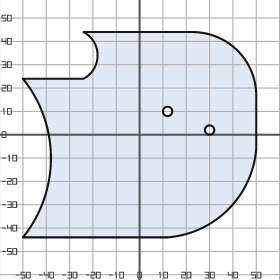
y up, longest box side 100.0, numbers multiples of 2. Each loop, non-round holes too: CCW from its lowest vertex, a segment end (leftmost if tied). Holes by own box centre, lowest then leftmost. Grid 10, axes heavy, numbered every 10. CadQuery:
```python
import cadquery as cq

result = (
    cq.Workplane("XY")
    .moveTo(-50.0, -44.0)
    .lineTo(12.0, -44.0)
    .threePointArc((38.0, -32.0), (50.0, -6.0))
    .lineTo(50.0, 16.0)
    .threePointArc((42.0, 36.0), (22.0, 44.0))
    .lineTo(-24.0, 44.0)
    .threePointArc((-18.0, 34.0), (-24.0, 24.0))
    .lineTo(-50.0, 24.0)
    .threePointArc((-38.0, -10.0), (-50.0, -44.0))
    .close()
    .moveTo(30.0, 2.0)
    .circle(2.0)
    .moveTo(12.0, 10.0)
    .circle(2.0)
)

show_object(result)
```